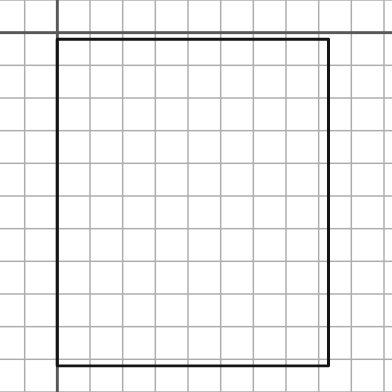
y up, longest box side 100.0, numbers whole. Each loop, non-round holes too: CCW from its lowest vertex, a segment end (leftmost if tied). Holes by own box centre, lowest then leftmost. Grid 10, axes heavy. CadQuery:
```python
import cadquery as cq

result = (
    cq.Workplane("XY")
    .moveTo(0.0, -102.0)
    .lineTo(83.0, -102.0)
    .lineTo(83.0, -2.0)
    .lineTo(0.0, -2.0)
    .close()
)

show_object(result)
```